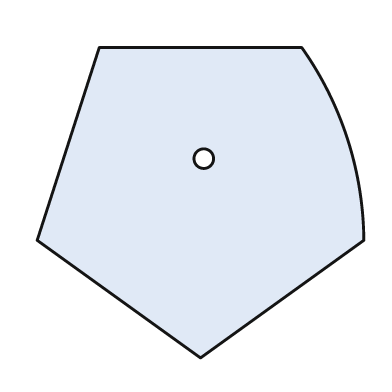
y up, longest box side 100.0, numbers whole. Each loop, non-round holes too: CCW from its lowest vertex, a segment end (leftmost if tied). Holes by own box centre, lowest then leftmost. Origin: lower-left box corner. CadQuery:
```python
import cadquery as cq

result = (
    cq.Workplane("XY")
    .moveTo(50.0, 0.0)
    .lineTo(100.0, 36.0)
    .threePointArc((95.0, 67.0), (81.0, 95.0))
    .lineTo(19.0, 95.0)
    .lineTo(0.0, 36.0)
    .close()
    .moveTo(51.0, 61.0)
    .circle(3.0)
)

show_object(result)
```